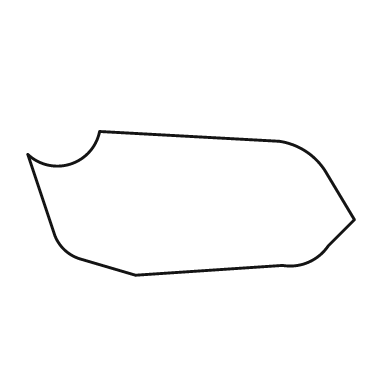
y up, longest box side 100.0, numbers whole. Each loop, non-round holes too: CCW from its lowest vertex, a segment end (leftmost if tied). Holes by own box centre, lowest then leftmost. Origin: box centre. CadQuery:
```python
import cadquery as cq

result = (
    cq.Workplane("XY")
    .moveTo(-17.0, -22.0)
    .lineTo(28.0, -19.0)
    .threePointArc((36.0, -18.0), (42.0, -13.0))
    .lineTo(50.0, -5.0)
    .lineTo(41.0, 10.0)
    .threePointArc((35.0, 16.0), (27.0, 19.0))
    .lineTo(-28.0, 22.0)
    .threePointArc((-37.0, 12.0), (-50.0, 15.0))
    .lineTo(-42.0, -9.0)
    .threePointArc((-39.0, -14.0), (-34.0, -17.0))
    .close()
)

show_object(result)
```